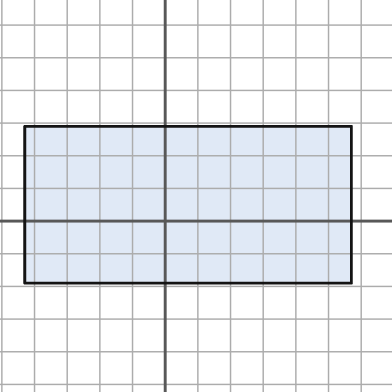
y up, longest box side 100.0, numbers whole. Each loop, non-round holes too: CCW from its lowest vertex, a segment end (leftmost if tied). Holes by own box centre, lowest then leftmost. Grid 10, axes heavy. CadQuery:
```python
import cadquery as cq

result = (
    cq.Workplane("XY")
    .moveTo(-43.0, -19.0)
    .lineTo(57.0, -19.0)
    .lineTo(57.0, 29.0)
    .lineTo(-43.0, 29.0)
    .close()
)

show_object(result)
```